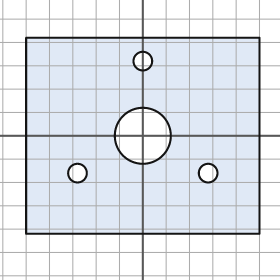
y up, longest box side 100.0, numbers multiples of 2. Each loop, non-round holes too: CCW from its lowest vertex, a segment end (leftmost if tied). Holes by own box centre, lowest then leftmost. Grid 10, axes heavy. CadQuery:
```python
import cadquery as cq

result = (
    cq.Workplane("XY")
    .moveTo(-50.0, -42.0)
    .lineTo(50.0, -42.0)
    .lineTo(50.0, 42.0)
    .lineTo(-50.0, 42.0)
    .close()
    .moveTo(-28.0, -16.0)
    .circle(4.0)
    .moveTo(28.0, -16.0)
    .circle(4.0)
    .moveTo(0.0, 0.0)
    .circle(12.0)
    .moveTo(0.0, 32.0)
    .circle(4.0)
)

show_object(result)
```